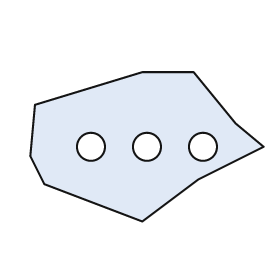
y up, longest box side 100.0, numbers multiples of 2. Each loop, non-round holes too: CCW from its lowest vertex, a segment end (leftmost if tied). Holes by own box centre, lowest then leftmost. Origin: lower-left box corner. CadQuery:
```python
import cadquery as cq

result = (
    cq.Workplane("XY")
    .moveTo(48.0, 0.0)
    .lineTo(72.0, 18.0)
    .lineTo(100.0, 32.0)
    .lineTo(88.0, 42.0)
    .lineTo(70.0, 64.0)
    .lineTo(48.0, 64.0)
    .lineTo(2.0, 50.0)
    .lineTo(0.0, 28.0)
    .lineTo(6.0, 16.0)
    .close()
    .moveTo(26.0, 32.0)
    .circle(6.0)
    .moveTo(50.0, 32.0)
    .circle(6.0)
    .moveTo(74.0, 32.0)
    .circle(6.0)
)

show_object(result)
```